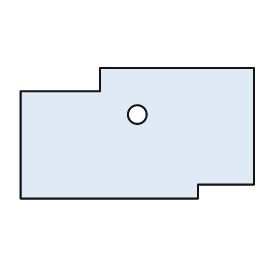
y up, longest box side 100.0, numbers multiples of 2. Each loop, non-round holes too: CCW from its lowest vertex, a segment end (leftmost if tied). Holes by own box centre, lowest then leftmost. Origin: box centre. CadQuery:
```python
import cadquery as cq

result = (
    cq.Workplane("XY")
    .moveTo(-50.0, -28.0)
    .lineTo(26.0, -28.0)
    .lineTo(26.0, -22.0)
    .lineTo(50.0, -22.0)
    .lineTo(50.0, 28.0)
    .lineTo(-16.0, 28.0)
    .lineTo(-16.0, 18.0)
    .lineTo(-50.0, 18.0)
    .close()
    .moveTo(0.0, 8.0)
    .circle(4.0)
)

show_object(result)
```